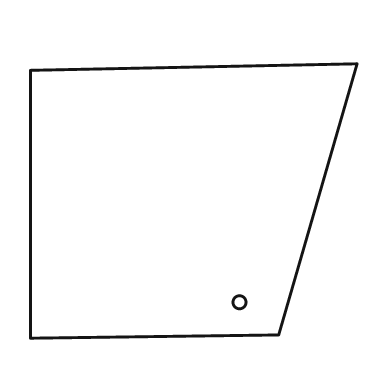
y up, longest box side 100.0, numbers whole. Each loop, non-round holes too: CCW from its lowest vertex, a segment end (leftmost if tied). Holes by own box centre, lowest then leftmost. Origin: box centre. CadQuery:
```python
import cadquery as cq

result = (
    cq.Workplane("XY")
    .moveTo(-50.0, -42.0)
    .lineTo(26.0, -41.0)
    .lineTo(50.0, 42.0)
    .lineTo(-50.0, 40.0)
    .close()
    .moveTo(14.0, -31.0)
    .circle(2.0)
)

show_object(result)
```